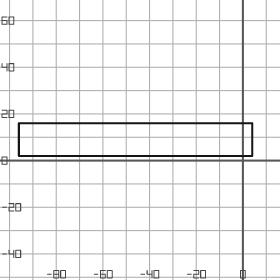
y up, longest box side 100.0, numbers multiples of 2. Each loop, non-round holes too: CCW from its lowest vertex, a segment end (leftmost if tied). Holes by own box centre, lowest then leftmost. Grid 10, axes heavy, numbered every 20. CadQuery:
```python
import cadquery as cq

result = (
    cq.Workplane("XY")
    .moveTo(-96.0, 2.0)
    .lineTo(4.0, 2.0)
    .lineTo(4.0, 16.0)
    .lineTo(-96.0, 16.0)
    .close()
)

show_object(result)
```